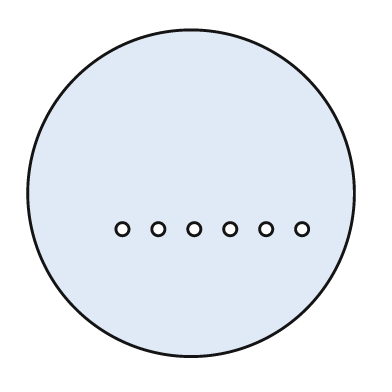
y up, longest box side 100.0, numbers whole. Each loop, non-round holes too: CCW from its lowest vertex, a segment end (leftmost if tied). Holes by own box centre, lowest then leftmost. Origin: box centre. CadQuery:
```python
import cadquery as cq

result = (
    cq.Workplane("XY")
    .moveTo(0.0, 0.0)
    .circle(50.0)
    .moveTo(-21.0, -11.0)
    .circle(2.0)
    .moveTo(-10.0, -11.0)
    .circle(2.0)
    .moveTo(1.0, -11.0)
    .circle(2.0)
    .moveTo(12.0, -11.0)
    .circle(2.0)
    .moveTo(23.0, -11.0)
    .circle(2.0)
    .moveTo(34.0, -11.0)
    .circle(2.0)
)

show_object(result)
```